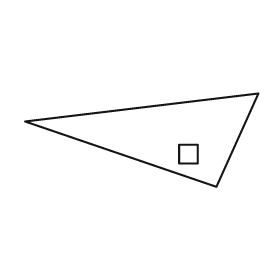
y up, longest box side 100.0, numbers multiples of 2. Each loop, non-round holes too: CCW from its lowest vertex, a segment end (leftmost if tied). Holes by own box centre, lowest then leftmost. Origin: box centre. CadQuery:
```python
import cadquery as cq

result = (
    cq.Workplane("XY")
    .moveTo(32.0, -20.0)
    .lineTo(50.0, 20.0)
    .lineTo(-50.0, 8.0)
    .close()
    .moveTo(16.0, -10.0)
    .lineTo(24.0, -10.0)
    .lineTo(24.0, -2.0)
    .lineTo(16.0, -2.0)
    .close()
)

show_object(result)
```